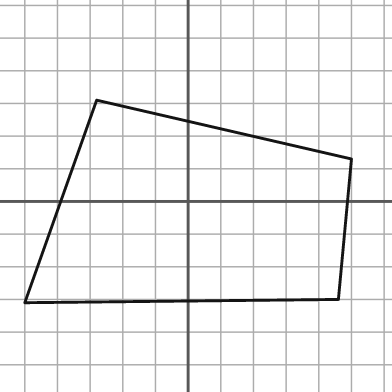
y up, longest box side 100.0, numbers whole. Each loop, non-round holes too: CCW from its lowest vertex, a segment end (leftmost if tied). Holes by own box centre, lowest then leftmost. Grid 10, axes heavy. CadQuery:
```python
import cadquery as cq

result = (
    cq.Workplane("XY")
    .moveTo(-50.0, -31.0)
    .lineTo(46.0, -30.0)
    .lineTo(50.0, 13.0)
    .lineTo(-28.0, 31.0)
    .close()
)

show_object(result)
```